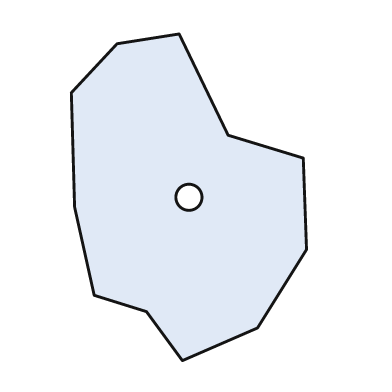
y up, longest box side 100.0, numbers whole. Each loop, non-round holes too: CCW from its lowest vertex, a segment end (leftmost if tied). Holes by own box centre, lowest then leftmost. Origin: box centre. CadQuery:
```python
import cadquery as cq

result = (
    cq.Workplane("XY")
    .moveTo(-2.0, -50.0)
    .lineTo(21.0, -40.0)
    .lineTo(36.0, -16.0)
    .lineTo(35.0, 12.0)
    .lineTo(12.0, 19.0)
    .lineTo(-3.0, 50.0)
    .lineTo(-22.0, 47.0)
    .lineTo(-36.0, 32.0)
    .lineTo(-35.0, -3.0)
    .lineTo(-29.0, -30.0)
    .lineTo(-13.0, -35.0)
    .close()
    .moveTo(0.0, 0.0)
    .circle(4.0)
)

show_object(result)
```